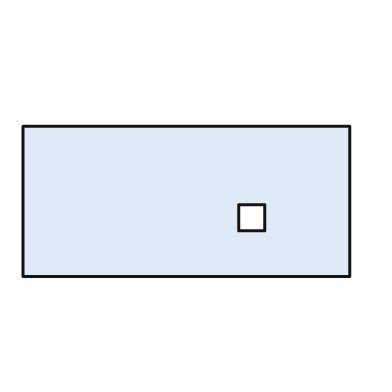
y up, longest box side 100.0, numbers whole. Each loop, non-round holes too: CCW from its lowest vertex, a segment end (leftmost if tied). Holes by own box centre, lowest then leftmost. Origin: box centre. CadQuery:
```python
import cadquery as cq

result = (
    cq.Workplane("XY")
    .moveTo(-50.0, -23.0)
    .lineTo(50.0, -23.0)
    .lineTo(50.0, 23.0)
    .lineTo(-50.0, 23.0)
    .close()
    .moveTo(16.0, -9.0)
    .lineTo(24.0, -9.0)
    .lineTo(24.0, -1.0)
    .lineTo(16.0, -1.0)
    .close()
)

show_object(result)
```